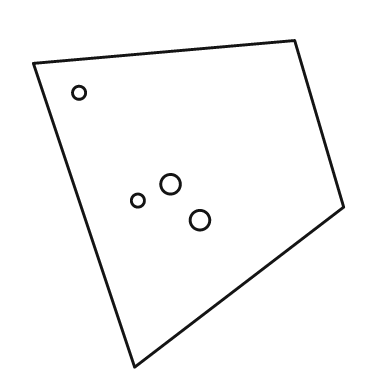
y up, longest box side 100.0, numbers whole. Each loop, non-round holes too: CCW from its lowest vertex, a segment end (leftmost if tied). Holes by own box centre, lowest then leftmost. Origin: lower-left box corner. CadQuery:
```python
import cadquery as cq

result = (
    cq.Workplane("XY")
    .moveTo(31.0, 0.0)
    .lineTo(95.0, 49.0)
    .lineTo(80.0, 100.0)
    .lineTo(0.0, 93.0)
    .close()
    .moveTo(51.0, 45.0)
    .circle(3.0)
    .moveTo(32.0, 51.0)
    .circle(2.0)
    .moveTo(42.0, 56.0)
    .circle(3.0)
    .moveTo(14.0, 84.0)
    .circle(2.0)
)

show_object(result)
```